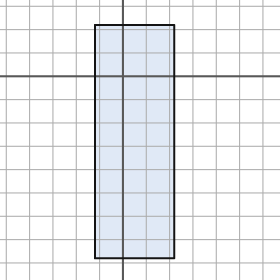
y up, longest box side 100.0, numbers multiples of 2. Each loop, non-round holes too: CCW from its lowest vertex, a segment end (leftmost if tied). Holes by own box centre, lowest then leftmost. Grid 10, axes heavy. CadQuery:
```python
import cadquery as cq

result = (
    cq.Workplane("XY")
    .moveTo(-12.0, -78.0)
    .lineTo(22.0, -78.0)
    .lineTo(22.0, 22.0)
    .lineTo(-12.0, 22.0)
    .close()
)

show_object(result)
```